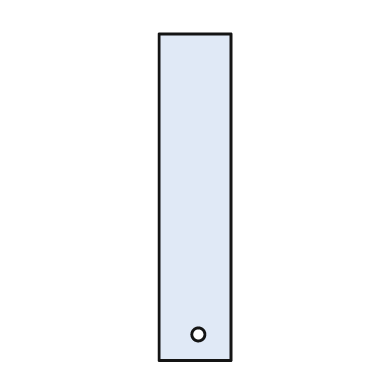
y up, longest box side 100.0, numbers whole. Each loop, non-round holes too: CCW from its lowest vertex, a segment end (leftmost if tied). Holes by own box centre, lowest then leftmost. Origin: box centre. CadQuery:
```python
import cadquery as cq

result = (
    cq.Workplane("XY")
    .moveTo(-11.0, -50.0)
    .lineTo(11.0, -50.0)
    .lineTo(11.0, 50.0)
    .lineTo(-11.0, 50.0)
    .close()
    .moveTo(1.0, -42.0)
    .circle(2.0)
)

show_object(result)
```